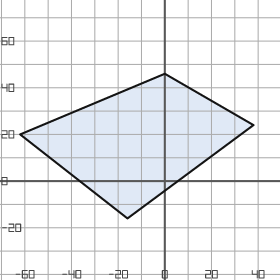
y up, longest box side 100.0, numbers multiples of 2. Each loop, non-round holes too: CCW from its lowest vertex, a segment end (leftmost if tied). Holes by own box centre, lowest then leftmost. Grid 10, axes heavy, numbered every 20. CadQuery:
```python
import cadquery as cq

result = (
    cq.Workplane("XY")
    .moveTo(-16.0, -16.0)
    .lineTo(38.0, 24.0)
    .lineTo(0.0, 46.0)
    .lineTo(-62.0, 20.0)
    .close()
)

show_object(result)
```